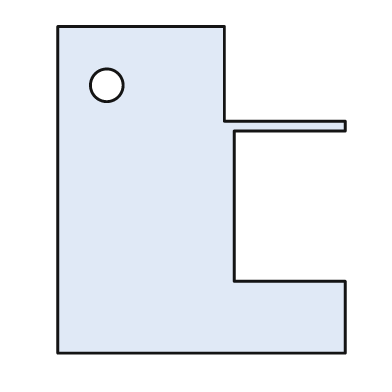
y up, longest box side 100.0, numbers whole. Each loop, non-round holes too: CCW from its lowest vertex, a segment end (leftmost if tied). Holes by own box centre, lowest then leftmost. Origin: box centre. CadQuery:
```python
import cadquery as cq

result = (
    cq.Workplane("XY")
    .moveTo(-44.0, -50.0)
    .lineTo(44.0, -50.0)
    .lineTo(44.0, -28.0)
    .lineTo(10.0, -28.0)
    .lineTo(10.0, 18.0)
    .lineTo(44.0, 18.0)
    .lineTo(44.0, 21.0)
    .lineTo(7.0, 21.0)
    .lineTo(7.0, 50.0)
    .lineTo(-44.0, 50.0)
    .close()
    .moveTo(-29.0, 32.0)
    .circle(5.0)
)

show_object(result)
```